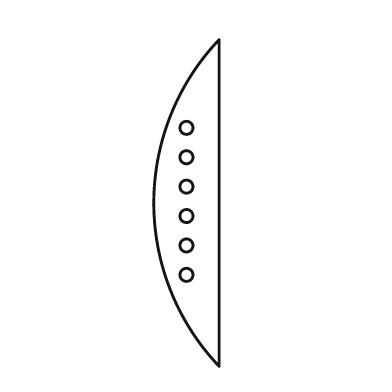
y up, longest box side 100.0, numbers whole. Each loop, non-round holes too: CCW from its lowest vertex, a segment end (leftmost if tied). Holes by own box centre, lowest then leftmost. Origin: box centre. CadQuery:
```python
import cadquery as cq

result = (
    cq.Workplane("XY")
    .moveTo(10.0, -50.0)
    .lineTo(10.0, 50.0)
    .threePointArc((-10.0, 0.0), (10.0, -50.0))
    .close()
    .moveTo(0.0, -22.0)
    .circle(2.0)
    .moveTo(0.0, -13.0)
    .circle(2.0)
    .moveTo(0.0, -4.0)
    .circle(2.0)
    .moveTo(0.0, 5.0)
    .circle(2.0)
    .moveTo(0.0, 14.0)
    .circle(2.0)
    .moveTo(0.0, 23.0)
    .circle(2.0)
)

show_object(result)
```